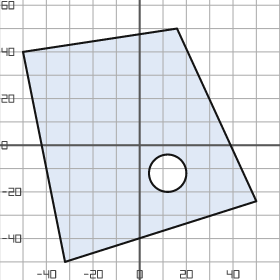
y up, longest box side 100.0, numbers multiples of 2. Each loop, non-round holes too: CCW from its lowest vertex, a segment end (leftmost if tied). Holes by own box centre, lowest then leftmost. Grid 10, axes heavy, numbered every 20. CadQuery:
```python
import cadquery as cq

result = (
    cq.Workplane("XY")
    .moveTo(-32.0, -50.0)
    .lineTo(50.0, -24.0)
    .lineTo(16.0, 50.0)
    .lineTo(-50.0, 40.0)
    .close()
    .moveTo(12.0, -12.0)
    .circle(8.0)
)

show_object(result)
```